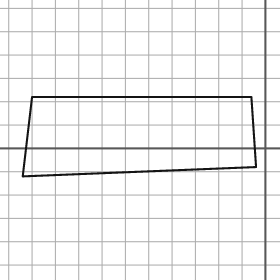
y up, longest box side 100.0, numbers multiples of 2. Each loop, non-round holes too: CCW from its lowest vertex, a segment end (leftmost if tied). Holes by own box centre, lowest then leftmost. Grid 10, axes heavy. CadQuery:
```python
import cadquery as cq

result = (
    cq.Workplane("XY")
    .moveTo(-104.0, -12.0)
    .lineTo(-4.0, -8.0)
    .lineTo(-6.0, 22.0)
    .lineTo(-100.0, 22.0)
    .close()
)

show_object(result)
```